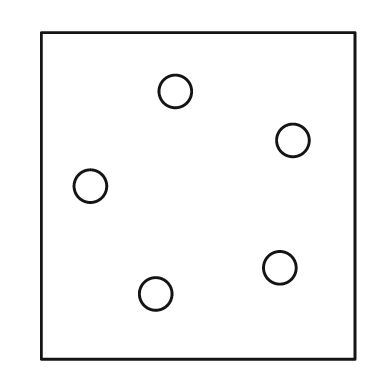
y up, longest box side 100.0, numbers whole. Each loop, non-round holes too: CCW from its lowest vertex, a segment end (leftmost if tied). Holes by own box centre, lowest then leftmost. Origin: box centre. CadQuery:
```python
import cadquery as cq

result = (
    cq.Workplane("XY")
    .moveTo(-48.0, -50.0)
    .lineTo(48.0, -50.0)
    .lineTo(48.0, 50.0)
    .lineTo(-48.0, 50.0)
    .close()
    .moveTo(-13.0, -30.0)
    .circle(5.0)
    .moveTo(25.0, -22.0)
    .circle(5.0)
    .moveTo(-33.0, 3.0)
    .circle(5.0)
    .moveTo(29.0, 17.0)
    .circle(5.0)
    .moveTo(-7.0, 32.0)
    .circle(5.0)
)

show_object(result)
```